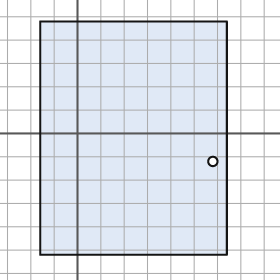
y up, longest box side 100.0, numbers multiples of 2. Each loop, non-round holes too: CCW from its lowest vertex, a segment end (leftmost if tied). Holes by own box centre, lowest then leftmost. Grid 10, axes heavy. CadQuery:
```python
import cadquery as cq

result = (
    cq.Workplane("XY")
    .moveTo(-16.0, -52.0)
    .lineTo(64.0, -52.0)
    .lineTo(64.0, 48.0)
    .lineTo(-16.0, 48.0)
    .close()
    .moveTo(58.0, -12.0)
    .circle(2.0)
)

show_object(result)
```